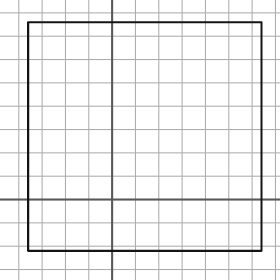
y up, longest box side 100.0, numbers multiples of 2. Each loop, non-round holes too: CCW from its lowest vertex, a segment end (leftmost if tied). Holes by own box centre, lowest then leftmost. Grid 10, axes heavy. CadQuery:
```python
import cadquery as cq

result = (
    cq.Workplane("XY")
    .moveTo(-36.0, -22.0)
    .lineTo(64.0, -22.0)
    .lineTo(64.0, 76.0)
    .lineTo(-36.0, 76.0)
    .close()
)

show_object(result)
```